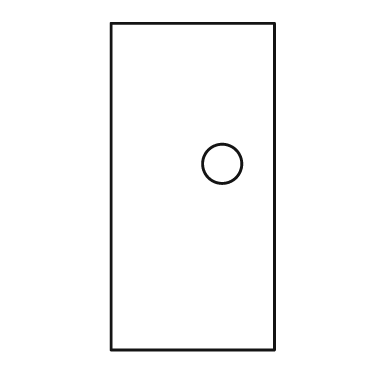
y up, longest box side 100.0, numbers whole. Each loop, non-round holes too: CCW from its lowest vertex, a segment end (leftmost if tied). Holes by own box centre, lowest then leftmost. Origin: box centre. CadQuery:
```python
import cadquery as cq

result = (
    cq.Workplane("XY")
    .moveTo(-25.0, -50.0)
    .lineTo(25.0, -50.0)
    .lineTo(25.0, 50.0)
    .lineTo(-25.0, 50.0)
    .close()
    .moveTo(9.0, 7.0)
    .circle(6.0)
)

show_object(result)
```